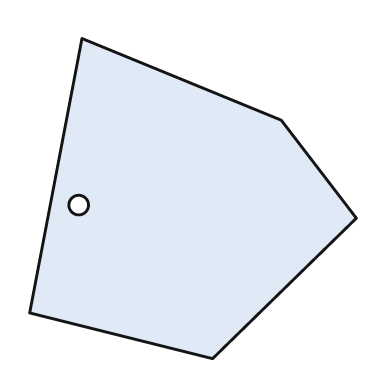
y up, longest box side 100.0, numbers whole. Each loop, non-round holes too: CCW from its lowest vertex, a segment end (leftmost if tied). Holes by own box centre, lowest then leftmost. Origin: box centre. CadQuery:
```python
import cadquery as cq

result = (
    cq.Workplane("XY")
    .moveTo(6.0, -49.0)
    .lineTo(50.0, -6.0)
    .lineTo(27.0, 24.0)
    .lineTo(-34.0, 49.0)
    .lineTo(-50.0, -35.0)
    .close()
    .moveTo(-35.0, -2.0)
    .circle(3.0)
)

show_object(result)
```